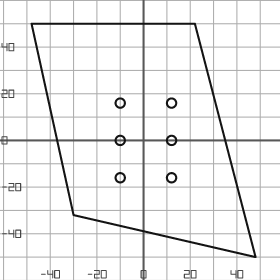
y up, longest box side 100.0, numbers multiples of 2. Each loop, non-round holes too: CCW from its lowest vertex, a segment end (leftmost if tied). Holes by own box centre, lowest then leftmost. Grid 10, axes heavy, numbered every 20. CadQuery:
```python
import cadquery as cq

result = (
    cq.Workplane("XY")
    .moveTo(48.0, -50.0)
    .lineTo(22.0, 50.0)
    .lineTo(-48.0, 50.0)
    .lineTo(-30.0, -32.0)
    .close()
    .moveTo(-10.0, -16.0)
    .circle(2.0)
    .moveTo(12.0, -16.0)
    .circle(2.0)
    .moveTo(-10.0, 0.0)
    .circle(2.0)
    .moveTo(12.0, 0.0)
    .circle(2.0)
    .moveTo(-10.0, 16.0)
    .circle(2.0)
    .moveTo(12.0, 16.0)
    .circle(2.0)
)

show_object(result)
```